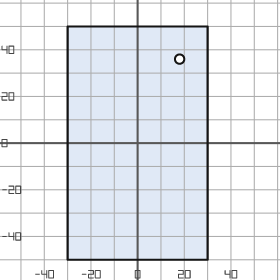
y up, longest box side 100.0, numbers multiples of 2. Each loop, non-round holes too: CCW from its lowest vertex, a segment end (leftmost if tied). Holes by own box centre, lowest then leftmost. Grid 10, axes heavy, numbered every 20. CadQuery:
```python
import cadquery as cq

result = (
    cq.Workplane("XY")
    .moveTo(-30.0, -50.0)
    .lineTo(30.0, -50.0)
    .lineTo(30.0, 50.0)
    .lineTo(-30.0, 50.0)
    .close()
    .moveTo(18.0, 36.0)
    .circle(2.0)
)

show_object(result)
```